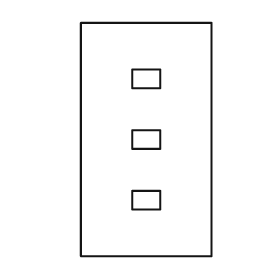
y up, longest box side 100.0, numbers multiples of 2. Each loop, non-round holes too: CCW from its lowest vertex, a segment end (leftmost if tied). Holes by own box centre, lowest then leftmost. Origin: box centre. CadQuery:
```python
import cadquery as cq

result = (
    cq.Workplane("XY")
    .moveTo(-28.0, -50.0)
    .lineTo(28.0, -50.0)
    .lineTo(28.0, 50.0)
    .lineTo(-28.0, 50.0)
    .close()
    .moveTo(-6.0, -30.0)
    .lineTo(6.0, -30.0)
    .lineTo(6.0, -22.0)
    .lineTo(-6.0, -22.0)
    .close()
    .moveTo(-6.0, -4.0)
    .lineTo(6.0, -4.0)
    .lineTo(6.0, 4.0)
    .lineTo(-6.0, 4.0)
    .close()
    .moveTo(-6.0, 22.0)
    .lineTo(6.0, 22.0)
    .lineTo(6.0, 30.0)
    .lineTo(-6.0, 30.0)
    .close()
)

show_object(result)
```